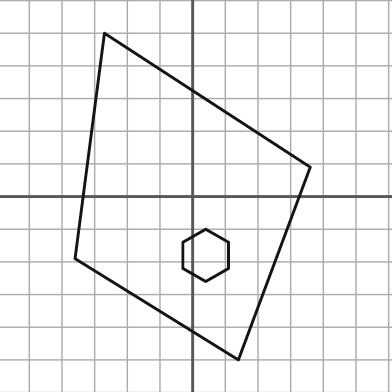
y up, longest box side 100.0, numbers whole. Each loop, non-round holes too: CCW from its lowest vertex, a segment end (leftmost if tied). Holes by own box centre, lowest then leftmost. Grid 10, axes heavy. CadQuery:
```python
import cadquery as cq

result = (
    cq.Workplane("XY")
    .moveTo(14.0, -50.0)
    .lineTo(36.0, 9.0)
    .lineTo(-27.0, 50.0)
    .lineTo(-36.0, -19.0)
    .close()
    .moveTo(4.0, -26.0)
    .lineTo(11.0, -22.0)
    .lineTo(11.0, -14.0)
    .lineTo(4.0, -10.0)
    .lineTo(-3.0, -14.0)
    .lineTo(-3.0, -22.0)
    .close()
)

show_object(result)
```